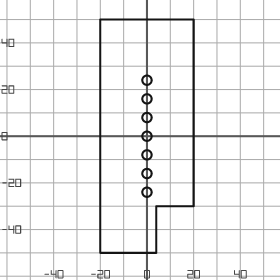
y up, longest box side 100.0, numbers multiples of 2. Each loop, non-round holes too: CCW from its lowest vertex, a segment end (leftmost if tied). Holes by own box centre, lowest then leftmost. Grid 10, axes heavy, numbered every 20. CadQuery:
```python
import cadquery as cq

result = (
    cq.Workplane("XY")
    .moveTo(-20.0, -50.0)
    .lineTo(4.0, -50.0)
    .lineTo(4.0, -30.0)
    .lineTo(20.0, -30.0)
    .lineTo(20.0, 50.0)
    .lineTo(-20.0, 50.0)
    .close()
    .moveTo(0.0, -24.0)
    .circle(2.0)
    .moveTo(0.0, -16.0)
    .circle(2.0)
    .moveTo(0.0, -8.0)
    .circle(2.0)
    .moveTo(0.0, 0.0)
    .circle(2.0)
    .moveTo(0.0, 8.0)
    .circle(2.0)
    .moveTo(0.0, 16.0)
    .circle(2.0)
    .moveTo(0.0, 24.0)
    .circle(2.0)
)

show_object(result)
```